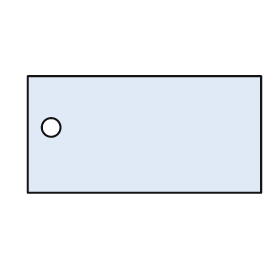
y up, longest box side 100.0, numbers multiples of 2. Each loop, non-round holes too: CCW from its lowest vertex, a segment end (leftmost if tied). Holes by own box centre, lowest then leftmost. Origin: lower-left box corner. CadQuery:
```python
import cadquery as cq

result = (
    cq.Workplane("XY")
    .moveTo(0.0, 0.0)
    .lineTo(100.0, 0.0)
    .lineTo(100.0, 50.0)
    .lineTo(0.0, 50.0)
    .close()
    .moveTo(10.0, 28.0)
    .circle(4.0)
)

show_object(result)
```